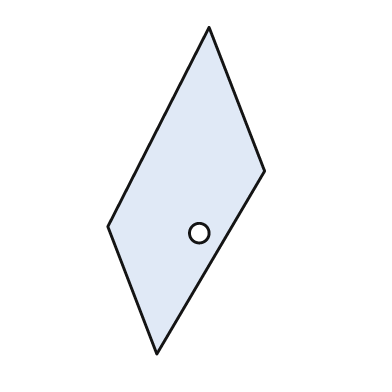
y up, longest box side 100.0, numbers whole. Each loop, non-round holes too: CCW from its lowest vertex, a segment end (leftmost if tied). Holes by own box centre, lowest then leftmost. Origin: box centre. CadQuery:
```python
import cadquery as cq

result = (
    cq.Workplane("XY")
    .moveTo(-9.0, -50.0)
    .lineTo(24.0, 6.0)
    .lineTo(7.0, 50.0)
    .lineTo(-24.0, -11.0)
    .close()
    .moveTo(4.0, -13.0)
    .circle(3.0)
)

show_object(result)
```